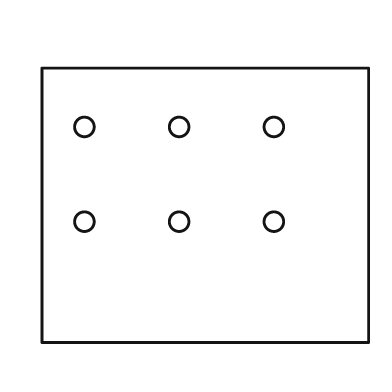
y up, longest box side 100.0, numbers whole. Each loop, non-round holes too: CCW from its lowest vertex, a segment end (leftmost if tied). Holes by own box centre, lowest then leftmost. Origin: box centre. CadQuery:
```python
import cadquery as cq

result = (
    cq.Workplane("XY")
    .moveTo(-50.0, -42.0)
    .lineTo(50.0, -42.0)
    .lineTo(50.0, 42.0)
    .lineTo(-50.0, 42.0)
    .close()
    .moveTo(-37.0, -5.0)
    .circle(3.0)
    .moveTo(-8.0, -5.0)
    .circle(3.0)
    .moveTo(21.0, -5.0)
    .circle(3.0)
    .moveTo(-37.0, 24.0)
    .circle(3.0)
    .moveTo(-8.0, 24.0)
    .circle(3.0)
    .moveTo(21.0, 24.0)
    .circle(3.0)
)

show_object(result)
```